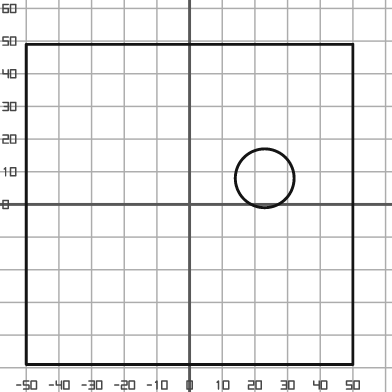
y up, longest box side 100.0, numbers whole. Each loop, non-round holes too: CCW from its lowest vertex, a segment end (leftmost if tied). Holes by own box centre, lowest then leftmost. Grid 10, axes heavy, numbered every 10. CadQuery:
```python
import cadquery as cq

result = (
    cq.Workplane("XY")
    .moveTo(-50.0, -49.0)
    .lineTo(50.0, -49.0)
    .lineTo(50.0, 49.0)
    .lineTo(-50.0, 49.0)
    .close()
    .moveTo(23.0, 8.0)
    .circle(9.0)
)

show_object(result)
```